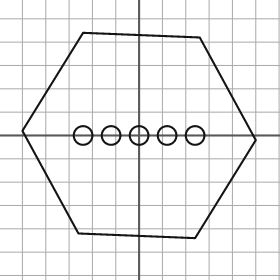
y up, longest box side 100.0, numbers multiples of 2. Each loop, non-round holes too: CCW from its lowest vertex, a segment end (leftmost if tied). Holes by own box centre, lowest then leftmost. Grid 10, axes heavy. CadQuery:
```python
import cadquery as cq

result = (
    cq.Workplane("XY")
    .moveTo(24.0, -44.0)
    .lineTo(50.0, -2.0)
    .lineTo(26.0, 42.0)
    .lineTo(-24.0, 44.0)
    .lineTo(-50.0, 2.0)
    .lineTo(-26.0, -42.0)
    .close()
    .moveTo(-24.0, 0.0)
    .circle(4.0)
    .moveTo(-12.0, 0.0)
    .circle(4.0)
    .moveTo(0.0, 0.0)
    .circle(4.0)
    .moveTo(12.0, 0.0)
    .circle(4.0)
    .moveTo(24.0, 0.0)
    .circle(4.0)
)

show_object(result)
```